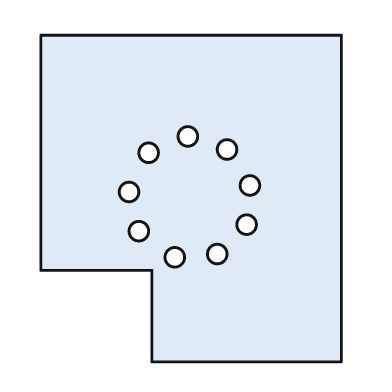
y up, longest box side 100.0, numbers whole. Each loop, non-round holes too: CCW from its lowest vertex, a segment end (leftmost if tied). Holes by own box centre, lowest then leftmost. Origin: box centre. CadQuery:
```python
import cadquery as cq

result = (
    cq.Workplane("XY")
    .moveTo(-12.0, -50.0)
    .lineTo(46.0, -50.0)
    .lineTo(46.0, 50.0)
    .lineTo(-46.0, 50.0)
    .lineTo(-46.0, -22.0)
    .lineTo(-12.0, -22.0)
    .close()
    .moveTo(-5.0, -18.0)
    .circle(3.0)
    .moveTo(8.0, -17.0)
    .circle(3.0)
    .moveTo(-16.0, -10.0)
    .circle(3.0)
    .moveTo(17.0, -8.0)
    .circle(3.0)
    .moveTo(-19.0, 2.0)
    .circle(3.0)
    .moveTo(18.0, 4.0)
    .circle(3.0)
    .moveTo(-13.0, 14.0)
    .circle(3.0)
    .moveTo(11.0, 15.0)
    .circle(3.0)
    .moveTo(-1.0, 19.0)
    .circle(3.0)
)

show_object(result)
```